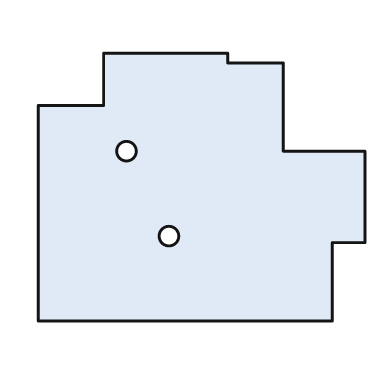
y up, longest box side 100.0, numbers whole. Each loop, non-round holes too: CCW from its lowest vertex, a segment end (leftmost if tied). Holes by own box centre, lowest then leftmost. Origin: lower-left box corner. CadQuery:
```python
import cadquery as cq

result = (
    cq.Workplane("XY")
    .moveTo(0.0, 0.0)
    .lineTo(90.0, 0.0)
    .lineTo(90.0, 24.0)
    .lineTo(100.0, 24.0)
    .lineTo(100.0, 52.0)
    .lineTo(75.0, 52.0)
    .lineTo(75.0, 79.0)
    .lineTo(58.0, 79.0)
    .lineTo(58.0, 82.0)
    .lineTo(20.0, 82.0)
    .lineTo(20.0, 66.0)
    .lineTo(0.0, 66.0)
    .close()
    .moveTo(40.0, 26.0)
    .circle(3.0)
    .moveTo(27.0, 52.0)
    .circle(3.0)
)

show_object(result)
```